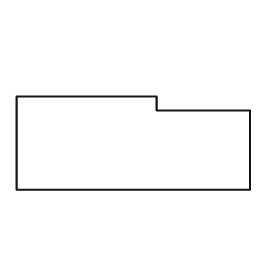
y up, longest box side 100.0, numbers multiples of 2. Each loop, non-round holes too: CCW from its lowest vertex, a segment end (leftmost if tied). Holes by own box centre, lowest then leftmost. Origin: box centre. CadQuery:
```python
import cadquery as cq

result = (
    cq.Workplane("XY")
    .moveTo(-50.0, -20.0)
    .lineTo(50.0, -20.0)
    .lineTo(50.0, 14.0)
    .lineTo(10.0, 14.0)
    .lineTo(10.0, 20.0)
    .lineTo(-50.0, 20.0)
    .close()
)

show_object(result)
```